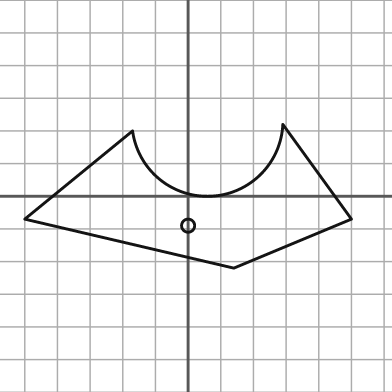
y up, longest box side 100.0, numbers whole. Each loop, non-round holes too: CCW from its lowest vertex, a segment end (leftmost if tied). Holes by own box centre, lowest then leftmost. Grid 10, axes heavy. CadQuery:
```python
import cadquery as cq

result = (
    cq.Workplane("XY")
    .moveTo(14.0, -22.0)
    .lineTo(50.0, -7.0)
    .lineTo(29.0, 22.0)
    .threePointArc((7.0, 0.0), (-17.0, 20.0))
    .lineTo(-50.0, -7.0)
    .close()
    .moveTo(0.0, -9.0)
    .circle(2.0)
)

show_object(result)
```